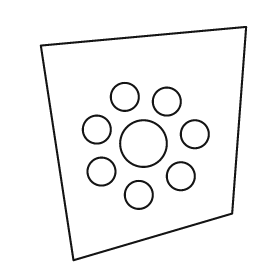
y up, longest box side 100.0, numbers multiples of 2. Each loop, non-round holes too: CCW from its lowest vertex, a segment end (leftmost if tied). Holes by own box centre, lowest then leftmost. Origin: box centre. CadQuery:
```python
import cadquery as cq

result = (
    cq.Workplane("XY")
    .moveTo(-30.0, -50.0)
    .lineTo(38.0, -30.0)
    .lineTo(44.0, 50.0)
    .lineTo(-44.0, 42.0)
    .close()
    .moveTo(-2.0, -22.0)
    .circle(6.0)
    .moveTo(16.0, -14.0)
    .circle(6.0)
    .moveTo(-18.0, -12.0)
    .circle(6.0)
    .moveTo(0.0, 0.0)
    .circle(10.0)
    .moveTo(22.0, 4.0)
    .circle(6.0)
    .moveTo(-20.0, 6.0)
    .circle(6.0)
    .moveTo(10.0, 18.0)
    .circle(6.0)
    .moveTo(-8.0, 20.0)
    .circle(6.0)
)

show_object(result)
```